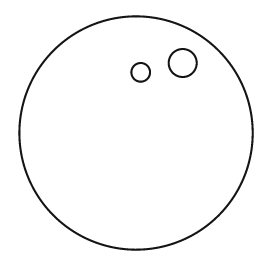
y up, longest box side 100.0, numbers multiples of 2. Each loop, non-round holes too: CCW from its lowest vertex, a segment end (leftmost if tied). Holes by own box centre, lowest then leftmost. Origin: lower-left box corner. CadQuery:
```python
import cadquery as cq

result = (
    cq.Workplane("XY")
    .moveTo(50.0, 50.0)
    .circle(50.0)
    .moveTo(52.0, 76.0)
    .circle(4.0)
    .moveTo(70.0, 80.0)
    .circle(6.0)
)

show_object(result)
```